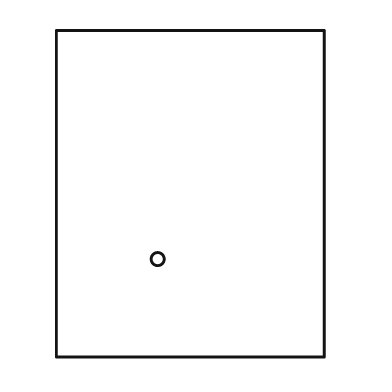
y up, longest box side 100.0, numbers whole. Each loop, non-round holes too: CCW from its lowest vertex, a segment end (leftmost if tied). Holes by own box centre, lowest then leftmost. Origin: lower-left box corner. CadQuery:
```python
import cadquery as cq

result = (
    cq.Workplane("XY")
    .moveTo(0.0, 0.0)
    .lineTo(82.0, 0.0)
    .lineTo(82.0, 100.0)
    .lineTo(0.0, 100.0)
    .close()
    .moveTo(31.0, 30.0)
    .circle(2.0)
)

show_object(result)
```